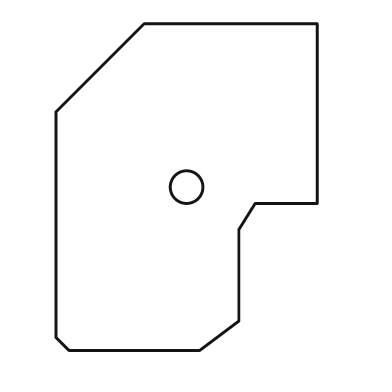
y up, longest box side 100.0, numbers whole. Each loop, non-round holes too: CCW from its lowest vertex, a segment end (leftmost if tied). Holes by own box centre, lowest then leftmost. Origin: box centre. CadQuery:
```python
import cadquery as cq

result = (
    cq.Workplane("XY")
    .moveTo(-36.0, -50.0)
    .lineTo(4.0, -50.0)
    .lineTo(16.0, -41.0)
    .lineTo(16.0, -13.0)
    .lineTo(21.0, -5.0)
    .lineTo(40.0, -5.0)
    .lineTo(40.0, 50.0)
    .lineTo(-13.0, 50.0)
    .lineTo(-40.0, 23.0)
    .lineTo(-40.0, -46.0)
    .close()
    .moveTo(0.0, 0.0)
    .circle(5.0)
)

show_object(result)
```